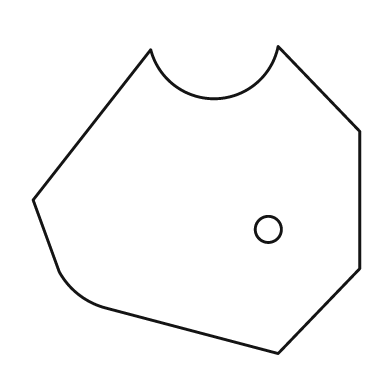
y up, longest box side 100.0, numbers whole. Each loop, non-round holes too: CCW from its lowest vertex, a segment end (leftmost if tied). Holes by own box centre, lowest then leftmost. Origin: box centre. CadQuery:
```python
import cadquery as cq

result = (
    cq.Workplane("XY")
    .moveTo(25.0, -47.0)
    .lineTo(50.0, -21.0)
    .lineTo(50.0, 21.0)
    .lineTo(25.0, 47.0)
    .threePointArc((6.0, 31.0), (-14.0, 46.0))
    .lineTo(-50.0, 0.0)
    .lineTo(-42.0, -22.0)
    .threePointArc((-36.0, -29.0), (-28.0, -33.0))
    .close()
    .moveTo(22.0, -9.0)
    .circle(4.0)
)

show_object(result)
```